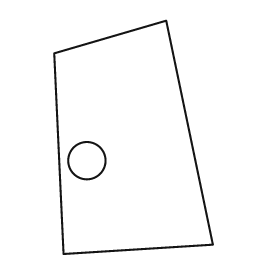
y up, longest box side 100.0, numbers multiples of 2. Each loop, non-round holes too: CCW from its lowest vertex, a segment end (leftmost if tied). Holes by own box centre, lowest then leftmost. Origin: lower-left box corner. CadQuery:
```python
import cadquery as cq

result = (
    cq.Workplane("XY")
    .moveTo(4.0, 0.0)
    .lineTo(68.0, 4.0)
    .lineTo(48.0, 100.0)
    .lineTo(0.0, 86.0)
    .close()
    .moveTo(14.0, 40.0)
    .circle(8.0)
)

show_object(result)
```